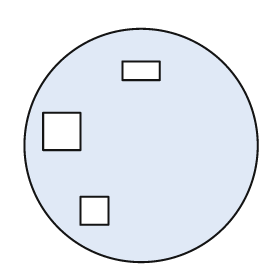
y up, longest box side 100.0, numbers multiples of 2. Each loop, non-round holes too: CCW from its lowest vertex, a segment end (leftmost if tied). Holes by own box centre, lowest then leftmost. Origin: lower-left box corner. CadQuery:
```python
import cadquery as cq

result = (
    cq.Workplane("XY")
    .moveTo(50.0, 50.0)
    .circle(50.0)
    .moveTo(24.0, 16.0)
    .lineTo(36.0, 16.0)
    .lineTo(36.0, 28.0)
    .lineTo(24.0, 28.0)
    .close()
    .moveTo(8.0, 48.0)
    .lineTo(24.0, 48.0)
    .lineTo(24.0, 64.0)
    .lineTo(8.0, 64.0)
    .close()
    .moveTo(42.0, 78.0)
    .lineTo(58.0, 78.0)
    .lineTo(58.0, 86.0)
    .lineTo(42.0, 86.0)
    .close()
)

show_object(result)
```